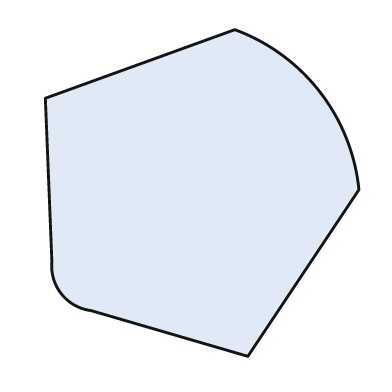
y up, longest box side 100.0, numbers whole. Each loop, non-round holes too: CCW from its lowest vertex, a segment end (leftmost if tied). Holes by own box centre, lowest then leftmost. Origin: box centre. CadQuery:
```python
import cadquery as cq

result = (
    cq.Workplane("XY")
    .moveTo(14.0, -50.0)
    .lineTo(48.0, 1.0)
    .threePointArc((36.0, 31.0), (10.0, 50.0))
    .lineTo(-48.0, 29.0)
    .lineTo(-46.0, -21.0)
    .threePointArc((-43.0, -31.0), (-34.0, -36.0))
    .close()
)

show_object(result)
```